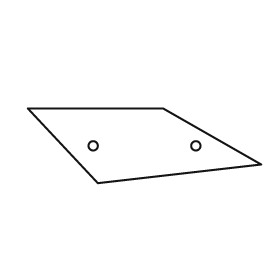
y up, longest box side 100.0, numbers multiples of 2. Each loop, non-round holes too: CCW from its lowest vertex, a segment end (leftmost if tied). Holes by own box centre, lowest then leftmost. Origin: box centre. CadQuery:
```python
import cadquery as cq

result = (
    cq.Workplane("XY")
    .moveTo(-20.0, -16.0)
    .lineTo(50.0, -8.0)
    .lineTo(8.0, 16.0)
    .lineTo(-50.0, 16.0)
    .close()
    .moveTo(-22.0, 0.0)
    .circle(2.0)
    .moveTo(22.0, 0.0)
    .circle(2.0)
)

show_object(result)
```